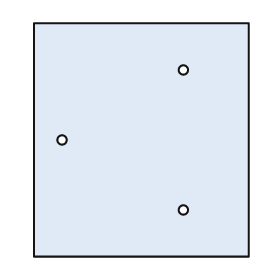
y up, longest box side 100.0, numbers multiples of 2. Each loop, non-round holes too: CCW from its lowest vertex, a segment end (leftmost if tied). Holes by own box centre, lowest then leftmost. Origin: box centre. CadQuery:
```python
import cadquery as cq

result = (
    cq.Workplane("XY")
    .moveTo(-46.0, -50.0)
    .lineTo(46.0, -50.0)
    .lineTo(46.0, 50.0)
    .lineTo(-46.0, 50.0)
    .close()
    .moveTo(18.0, -30.0)
    .circle(2.0)
    .moveTo(-34.0, 0.0)
    .circle(2.0)
    .moveTo(18.0, 30.0)
    .circle(2.0)
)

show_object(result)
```